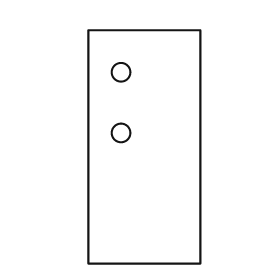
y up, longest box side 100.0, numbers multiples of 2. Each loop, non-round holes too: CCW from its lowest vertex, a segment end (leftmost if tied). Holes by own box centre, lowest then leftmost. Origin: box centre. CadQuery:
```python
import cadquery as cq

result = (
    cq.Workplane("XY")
    .moveTo(-24.0, -50.0)
    .lineTo(24.0, -50.0)
    .lineTo(24.0, 50.0)
    .lineTo(-24.0, 50.0)
    .close()
    .moveTo(-10.0, 6.0)
    .circle(4.0)
    .moveTo(-10.0, 32.0)
    .circle(4.0)
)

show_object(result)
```